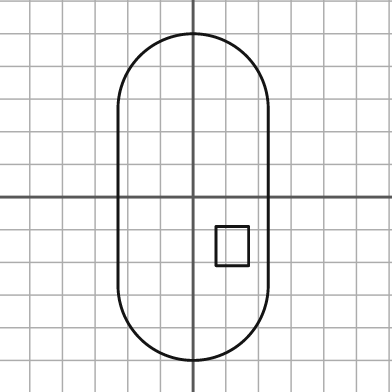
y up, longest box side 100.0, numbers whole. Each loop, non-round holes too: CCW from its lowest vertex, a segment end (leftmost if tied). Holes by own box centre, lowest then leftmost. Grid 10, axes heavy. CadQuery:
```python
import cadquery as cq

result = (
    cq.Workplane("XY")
    .moveTo(-23.0, -27.0)
    .threePointArc((0.0, -50.0), (23.0, -27.0))
    .lineTo(23.0, 27.0)
    .threePointArc((0.0, 50.0), (-23.0, 27.0))
    .close()
    .moveTo(7.0, -21.0)
    .lineTo(17.0, -21.0)
    .lineTo(17.0, -9.0)
    .lineTo(7.0, -9.0)
    .close()
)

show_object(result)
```